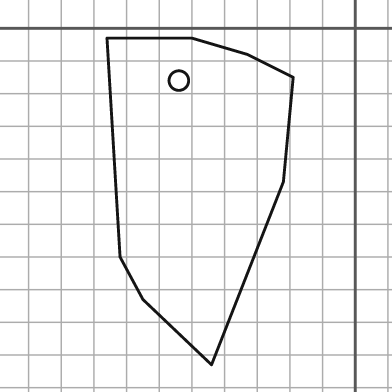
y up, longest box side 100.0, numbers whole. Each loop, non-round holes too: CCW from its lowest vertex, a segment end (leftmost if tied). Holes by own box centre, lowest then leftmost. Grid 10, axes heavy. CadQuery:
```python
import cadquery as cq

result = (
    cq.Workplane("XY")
    .moveTo(-44.0, -103.0)
    .lineTo(-22.0, -47.0)
    .lineTo(-19.0, -15.0)
    .lineTo(-33.0, -8.0)
    .lineTo(-50.0, -3.0)
    .lineTo(-76.0, -3.0)
    .lineTo(-72.0, -70.0)
    .lineTo(-65.0, -83.0)
    .close()
    .moveTo(-54.0, -16.0)
    .circle(3.0)
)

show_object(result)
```